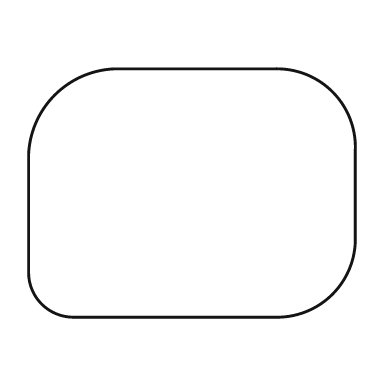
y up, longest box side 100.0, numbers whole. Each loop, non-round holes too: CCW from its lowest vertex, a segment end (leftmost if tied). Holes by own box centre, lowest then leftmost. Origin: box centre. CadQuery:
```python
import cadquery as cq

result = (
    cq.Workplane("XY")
    .moveTo(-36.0, -38.0)
    .lineTo(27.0, -38.0)
    .threePointArc((43.0, -31.0), (50.0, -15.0))
    .lineTo(50.0, 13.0)
    .threePointArc((43.0, 31.0), (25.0, 38.0))
    .lineTo(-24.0, 38.0)
    .threePointArc((-42.0, 30.0), (-50.0, 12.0))
    .lineTo(-50.0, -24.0)
    .threePointArc((-46.0, -34.0), (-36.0, -38.0))
    .close()
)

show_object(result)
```